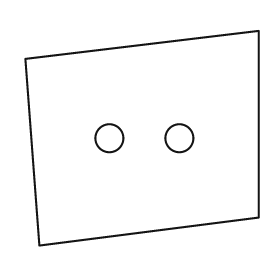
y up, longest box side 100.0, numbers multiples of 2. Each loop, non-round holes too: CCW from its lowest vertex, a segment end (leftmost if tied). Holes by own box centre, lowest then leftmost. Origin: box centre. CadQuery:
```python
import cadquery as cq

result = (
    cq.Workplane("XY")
    .moveTo(-44.0, -46.0)
    .lineTo(50.0, -34.0)
    .lineTo(50.0, 46.0)
    .lineTo(-50.0, 34.0)
    .close()
    .moveTo(-14.0, 0.0)
    .circle(6.0)
    .moveTo(16.0, 0.0)
    .circle(6.0)
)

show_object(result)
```